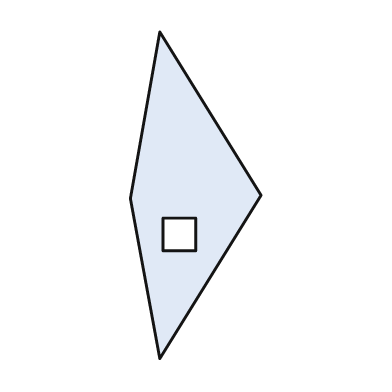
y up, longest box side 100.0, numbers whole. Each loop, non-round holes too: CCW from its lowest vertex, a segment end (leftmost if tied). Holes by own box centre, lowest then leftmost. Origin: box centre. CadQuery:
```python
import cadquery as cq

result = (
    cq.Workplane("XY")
    .moveTo(-11.0, -50.0)
    .lineTo(20.0, 0.0)
    .lineTo(-11.0, 50.0)
    .lineTo(-20.0, -1.0)
    .close()
    .moveTo(-10.0, -17.0)
    .lineTo(0.0, -17.0)
    .lineTo(0.0, -7.0)
    .lineTo(-10.0, -7.0)
    .close()
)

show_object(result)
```